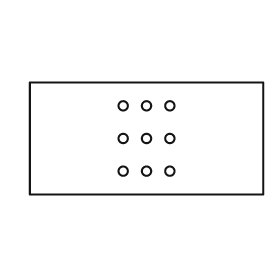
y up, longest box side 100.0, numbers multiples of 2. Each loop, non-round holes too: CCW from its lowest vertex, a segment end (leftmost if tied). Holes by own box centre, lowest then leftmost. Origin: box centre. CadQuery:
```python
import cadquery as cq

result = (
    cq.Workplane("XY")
    .moveTo(-50.0, -24.0)
    .lineTo(50.0, -24.0)
    .lineTo(50.0, 24.0)
    .lineTo(-50.0, 24.0)
    .close()
    .moveTo(-10.0, -14.0)
    .circle(2.0)
    .moveTo(0.0, -14.0)
    .circle(2.0)
    .moveTo(10.0, -14.0)
    .circle(2.0)
    .moveTo(-10.0, 0.0)
    .circle(2.0)
    .moveTo(0.0, 0.0)
    .circle(2.0)
    .moveTo(10.0, 0.0)
    .circle(2.0)
    .moveTo(-10.0, 14.0)
    .circle(2.0)
    .moveTo(0.0, 14.0)
    .circle(2.0)
    .moveTo(10.0, 14.0)
    .circle(2.0)
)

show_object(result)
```